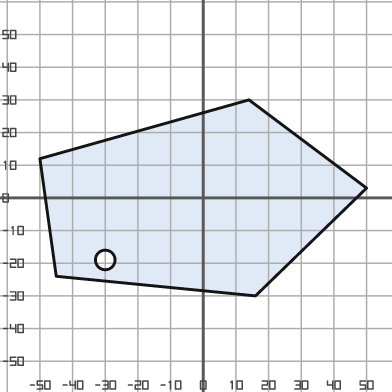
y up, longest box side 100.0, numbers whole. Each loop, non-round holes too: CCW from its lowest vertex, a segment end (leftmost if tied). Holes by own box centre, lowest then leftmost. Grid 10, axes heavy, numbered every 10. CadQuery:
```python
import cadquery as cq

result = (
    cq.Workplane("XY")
    .moveTo(16.0, -30.0)
    .lineTo(50.0, 3.0)
    .lineTo(14.0, 30.0)
    .lineTo(-50.0, 12.0)
    .lineTo(-45.0, -24.0)
    .close()
    .moveTo(-30.0, -19.0)
    .circle(3.0)
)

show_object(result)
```